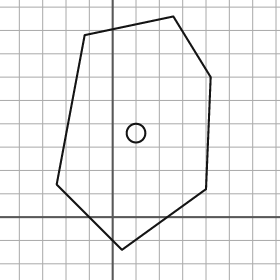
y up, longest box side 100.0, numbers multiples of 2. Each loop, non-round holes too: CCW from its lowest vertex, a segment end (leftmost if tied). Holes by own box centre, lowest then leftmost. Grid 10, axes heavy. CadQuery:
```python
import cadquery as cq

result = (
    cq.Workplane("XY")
    .moveTo(4.0, -14.0)
    .lineTo(40.0, 12.0)
    .lineTo(42.0, 60.0)
    .lineTo(26.0, 86.0)
    .lineTo(-12.0, 78.0)
    .lineTo(-24.0, 14.0)
    .close()
    .moveTo(10.0, 36.0)
    .circle(4.0)
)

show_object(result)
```